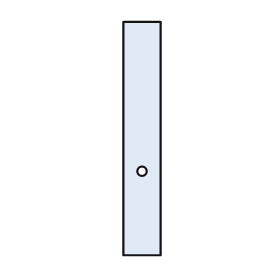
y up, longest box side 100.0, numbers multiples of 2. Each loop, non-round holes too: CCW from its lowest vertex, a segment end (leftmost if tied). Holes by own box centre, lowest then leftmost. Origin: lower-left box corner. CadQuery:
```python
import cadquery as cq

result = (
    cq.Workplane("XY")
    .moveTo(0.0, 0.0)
    .lineTo(16.0, 0.0)
    .lineTo(16.0, 100.0)
    .lineTo(0.0, 100.0)
    .close()
    .moveTo(8.0, 36.0)
    .circle(2.0)
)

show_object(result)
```